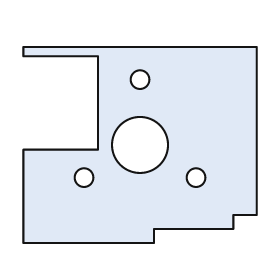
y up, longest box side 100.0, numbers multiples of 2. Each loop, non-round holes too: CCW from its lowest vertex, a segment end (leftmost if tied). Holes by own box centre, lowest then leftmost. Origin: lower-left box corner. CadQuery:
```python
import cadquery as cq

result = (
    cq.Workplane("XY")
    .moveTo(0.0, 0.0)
    .lineTo(56.0, 0.0)
    .lineTo(56.0, 6.0)
    .lineTo(90.0, 6.0)
    .lineTo(90.0, 12.0)
    .lineTo(100.0, 12.0)
    .lineTo(100.0, 84.0)
    .lineTo(0.0, 84.0)
    .lineTo(0.0, 80.0)
    .lineTo(32.0, 80.0)
    .lineTo(32.0, 40.0)
    .lineTo(0.0, 40.0)
    .close()
    .moveTo(26.0, 28.0)
    .circle(4.0)
    .moveTo(74.0, 28.0)
    .circle(4.0)
    .moveTo(50.0, 42.0)
    .circle(12.0)
    .moveTo(50.0, 70.0)
    .circle(4.0)
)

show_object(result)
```